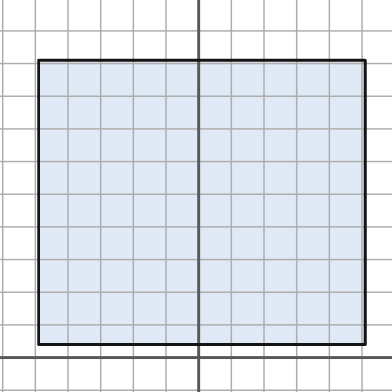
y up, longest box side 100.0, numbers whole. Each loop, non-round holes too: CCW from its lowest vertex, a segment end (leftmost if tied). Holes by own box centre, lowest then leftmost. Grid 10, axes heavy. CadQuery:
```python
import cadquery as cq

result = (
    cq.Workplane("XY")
    .moveTo(-49.0, 4.0)
    .lineTo(51.0, 4.0)
    .lineTo(51.0, 91.0)
    .lineTo(-49.0, 91.0)
    .close()
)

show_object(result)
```